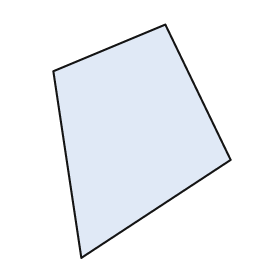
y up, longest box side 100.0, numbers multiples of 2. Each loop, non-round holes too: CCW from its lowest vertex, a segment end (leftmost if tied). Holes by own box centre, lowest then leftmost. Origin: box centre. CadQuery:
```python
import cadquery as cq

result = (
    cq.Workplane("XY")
    .moveTo(-26.0, -50.0)
    .lineTo(38.0, -8.0)
    .lineTo(10.0, 50.0)
    .lineTo(-38.0, 30.0)
    .close()
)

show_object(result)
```